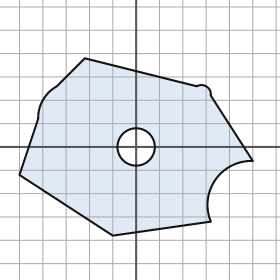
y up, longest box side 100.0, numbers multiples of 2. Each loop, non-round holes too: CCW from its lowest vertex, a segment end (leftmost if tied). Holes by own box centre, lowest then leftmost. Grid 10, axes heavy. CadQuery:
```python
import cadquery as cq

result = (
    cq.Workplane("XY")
    .moveTo(-10.0, -38.0)
    .lineTo(32.0, -32.0)
    .threePointArc((34.0, -14.0), (50.0, -6.0))
    .lineTo(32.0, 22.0)
    .threePointArc((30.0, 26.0), (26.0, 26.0))
    .lineTo(-22.0, 38.0)
    .lineTo(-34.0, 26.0)
    .threePointArc((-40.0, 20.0), (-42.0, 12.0))
    .lineTo(-50.0, -12.0)
    .close()
    .moveTo(0.0, 0.0)
    .circle(8.0)
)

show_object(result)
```